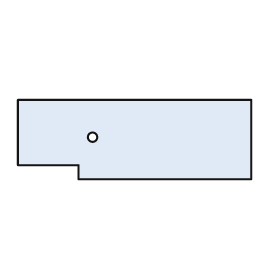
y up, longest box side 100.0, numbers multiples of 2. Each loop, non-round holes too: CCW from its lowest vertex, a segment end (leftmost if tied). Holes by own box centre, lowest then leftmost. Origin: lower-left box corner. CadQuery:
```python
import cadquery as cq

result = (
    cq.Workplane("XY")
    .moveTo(26.0, 0.0)
    .lineTo(100.0, 0.0)
    .lineTo(100.0, 34.0)
    .lineTo(0.0, 34.0)
    .lineTo(0.0, 6.0)
    .lineTo(26.0, 6.0)
    .close()
    .moveTo(32.0, 18.0)
    .circle(2.0)
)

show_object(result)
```